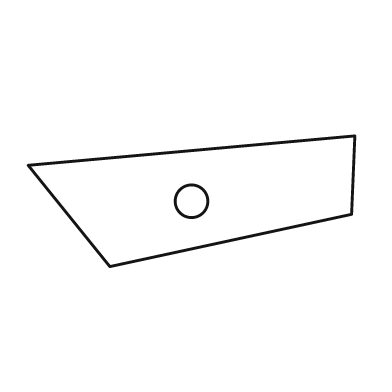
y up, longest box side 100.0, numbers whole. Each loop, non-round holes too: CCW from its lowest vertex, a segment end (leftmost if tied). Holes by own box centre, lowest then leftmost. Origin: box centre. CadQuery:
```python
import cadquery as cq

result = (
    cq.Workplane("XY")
    .moveTo(-25.0, -20.0)
    .lineTo(49.0, -4.0)
    .lineTo(50.0, 20.0)
    .lineTo(-50.0, 11.0)
    .close()
    .moveTo(0.0, 0.0)
    .circle(5.0)
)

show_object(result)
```